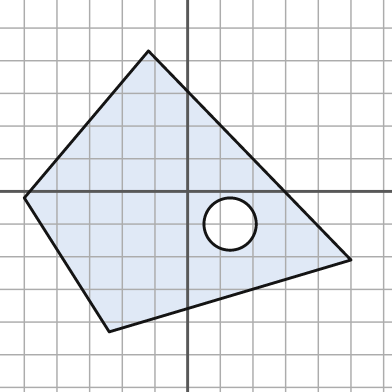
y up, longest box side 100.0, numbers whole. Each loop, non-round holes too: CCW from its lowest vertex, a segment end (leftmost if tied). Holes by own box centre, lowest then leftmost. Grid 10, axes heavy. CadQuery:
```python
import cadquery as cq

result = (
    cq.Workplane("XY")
    .moveTo(-24.0, -43.0)
    .lineTo(50.0, -21.0)
    .lineTo(-12.0, 43.0)
    .lineTo(-50.0, -2.0)
    .close()
    .moveTo(13.0, -10.0)
    .circle(8.0)
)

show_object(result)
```